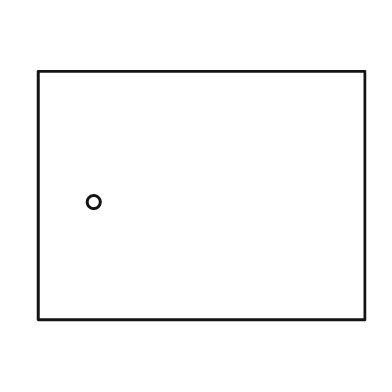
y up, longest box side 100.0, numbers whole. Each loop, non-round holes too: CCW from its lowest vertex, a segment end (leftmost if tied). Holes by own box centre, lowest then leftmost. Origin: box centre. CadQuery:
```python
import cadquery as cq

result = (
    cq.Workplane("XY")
    .moveTo(-50.0, -38.0)
    .lineTo(50.0, -38.0)
    .lineTo(50.0, 38.0)
    .lineTo(-50.0, 38.0)
    .close()
    .moveTo(-33.0, -2.0)
    .circle(2.0)
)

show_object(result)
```